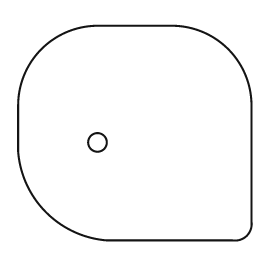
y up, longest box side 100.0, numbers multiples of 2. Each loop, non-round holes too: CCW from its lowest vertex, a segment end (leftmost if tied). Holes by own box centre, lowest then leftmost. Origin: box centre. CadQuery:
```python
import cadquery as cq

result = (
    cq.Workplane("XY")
    .moveTo(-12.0, -46.0)
    .lineTo(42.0, -46.0)
    .threePointArc((48.0, -44.0), (50.0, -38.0))
    .lineTo(50.0, 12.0)
    .threePointArc((40.0, 36.0), (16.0, 46.0))
    .lineTo(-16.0, 46.0)
    .threePointArc((-40.0, 36.0), (-50.0, 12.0))
    .lineTo(-50.0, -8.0)
    .threePointArc((-38.0, -34.0), (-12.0, -46.0))
    .close()
    .moveTo(-16.0, -4.0)
    .circle(4.0)
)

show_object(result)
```